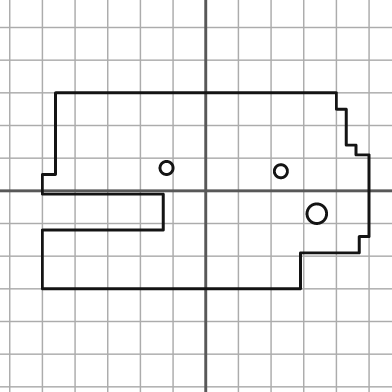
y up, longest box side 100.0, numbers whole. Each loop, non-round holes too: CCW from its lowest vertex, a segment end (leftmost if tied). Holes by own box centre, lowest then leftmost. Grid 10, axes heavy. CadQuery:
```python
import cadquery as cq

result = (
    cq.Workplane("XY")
    .moveTo(-50.0, -30.0)
    .lineTo(29.0, -30.0)
    .lineTo(29.0, -19.0)
    .lineTo(47.0, -19.0)
    .lineTo(47.0, -14.0)
    .lineTo(50.0, -14.0)
    .lineTo(50.0, 11.0)
    .lineTo(46.0, 11.0)
    .lineTo(46.0, 14.0)
    .lineTo(43.0, 14.0)
    .lineTo(43.0, 25.0)
    .lineTo(40.0, 25.0)
    .lineTo(40.0, 30.0)
    .lineTo(-46.0, 30.0)
    .lineTo(-46.0, 5.0)
    .lineTo(-50.0, 5.0)
    .lineTo(-50.0, -1.0)
    .lineTo(-13.0, -1.0)
    .lineTo(-13.0, -12.0)
    .lineTo(-50.0, -12.0)
    .close()
    .moveTo(34.0, -7.0)
    .circle(3.0)
    .moveTo(23.0, 6.0)
    .circle(2.0)
    .moveTo(-12.0, 7.0)
    .circle(2.0)
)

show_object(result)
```